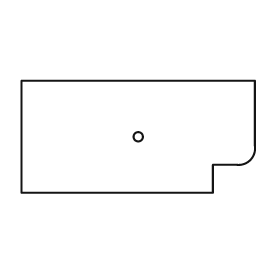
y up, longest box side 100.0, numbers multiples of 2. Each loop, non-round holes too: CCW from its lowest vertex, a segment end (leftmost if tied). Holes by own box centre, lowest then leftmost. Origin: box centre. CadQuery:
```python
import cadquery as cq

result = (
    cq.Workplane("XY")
    .moveTo(-50.0, -24.0)
    .lineTo(32.0, -24.0)
    .lineTo(32.0, -12.0)
    .lineTo(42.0, -12.0)
    .threePointArc((48.0, -10.0), (50.0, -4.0))
    .lineTo(50.0, 24.0)
    .lineTo(-50.0, 24.0)
    .close()
    .moveTo(0.0, 0.0)
    .circle(2.0)
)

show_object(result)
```